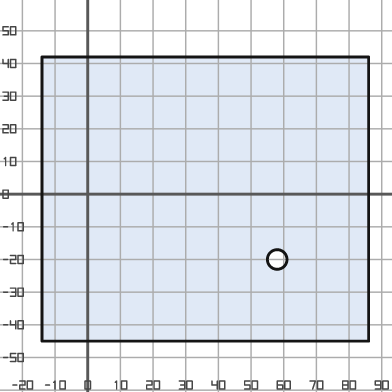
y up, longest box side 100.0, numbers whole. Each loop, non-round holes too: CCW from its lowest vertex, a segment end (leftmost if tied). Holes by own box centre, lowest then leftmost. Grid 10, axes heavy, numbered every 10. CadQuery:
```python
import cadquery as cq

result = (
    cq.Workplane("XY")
    .moveTo(-14.0, -45.0)
    .lineTo(86.0, -45.0)
    .lineTo(86.0, 42.0)
    .lineTo(-14.0, 42.0)
    .close()
    .moveTo(58.0, -20.0)
    .circle(3.0)
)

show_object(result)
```